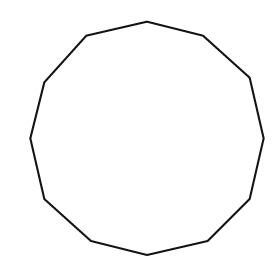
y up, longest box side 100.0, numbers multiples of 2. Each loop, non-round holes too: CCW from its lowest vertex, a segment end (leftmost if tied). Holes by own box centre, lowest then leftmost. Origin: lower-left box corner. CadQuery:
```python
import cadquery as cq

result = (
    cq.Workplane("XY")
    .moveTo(50.0, 0.0)
    .lineTo(76.0, 6.0)
    .lineTo(94.0, 24.0)
    .lineTo(100.0, 50.0)
    .lineTo(94.0, 76.0)
    .lineTo(74.0, 94.0)
    .lineTo(50.0, 100.0)
    .lineTo(24.0, 94.0)
    .lineTo(6.0, 74.0)
    .lineTo(0.0, 50.0)
    .lineTo(6.0, 24.0)
    .lineTo(26.0, 6.0)
    .close()
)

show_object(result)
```